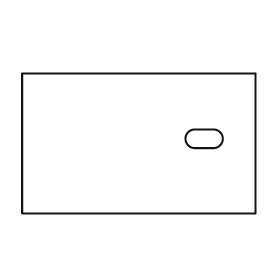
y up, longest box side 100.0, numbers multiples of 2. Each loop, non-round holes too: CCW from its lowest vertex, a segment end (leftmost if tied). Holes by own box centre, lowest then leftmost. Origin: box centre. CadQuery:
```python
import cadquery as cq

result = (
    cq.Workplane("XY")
    .moveTo(-50.0, -30.0)
    .lineTo(50.0, -30.0)
    .lineTo(50.0, 30.0)
    .lineTo(-50.0, 30.0)
    .close()
    .moveTo(24.0, -2.0)
    .lineTo(32.0, -2.0)
    .threePointArc((36.0, 2.0), (32.0, 6.0))
    .lineTo(24.0, 6.0)
    .threePointArc((20.0, 2.0), (24.0, -2.0))
    .close()
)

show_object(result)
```